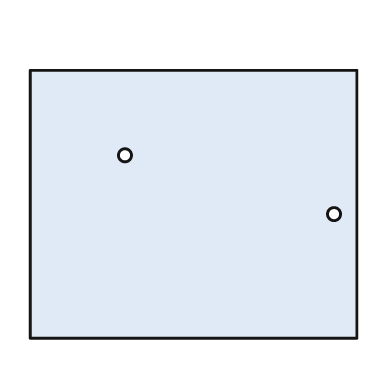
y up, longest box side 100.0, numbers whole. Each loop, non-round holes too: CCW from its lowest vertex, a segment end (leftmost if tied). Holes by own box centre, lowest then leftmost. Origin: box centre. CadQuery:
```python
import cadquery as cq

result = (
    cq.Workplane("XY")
    .moveTo(-50.0, -41.0)
    .lineTo(50.0, -41.0)
    .lineTo(50.0, 41.0)
    .lineTo(-50.0, 41.0)
    .close()
    .moveTo(43.0, -3.0)
    .circle(2.0)
    .moveTo(-21.0, 15.0)
    .circle(2.0)
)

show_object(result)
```